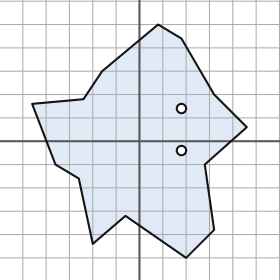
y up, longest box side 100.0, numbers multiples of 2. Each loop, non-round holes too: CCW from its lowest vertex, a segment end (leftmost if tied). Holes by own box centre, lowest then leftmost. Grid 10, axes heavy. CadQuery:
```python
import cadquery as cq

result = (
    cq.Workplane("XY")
    .moveTo(20.0, -50.0)
    .lineTo(32.0, -38.0)
    .lineTo(28.0, -10.0)
    .lineTo(46.0, 6.0)
    .lineTo(32.0, 20.0)
    .lineTo(18.0, 44.0)
    .lineTo(8.0, 50.0)
    .lineTo(-16.0, 30.0)
    .lineTo(-24.0, 18.0)
    .lineTo(-46.0, 16.0)
    .lineTo(-36.0, -10.0)
    .lineTo(-26.0, -16.0)
    .lineTo(-20.0, -44.0)
    .lineTo(-6.0, -32.0)
    .close()
    .moveTo(18.0, -4.0)
    .circle(2.0)
    .moveTo(18.0, 14.0)
    .circle(2.0)
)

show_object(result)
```